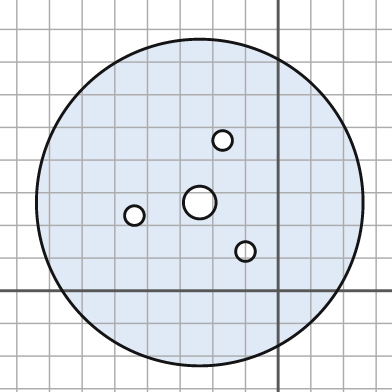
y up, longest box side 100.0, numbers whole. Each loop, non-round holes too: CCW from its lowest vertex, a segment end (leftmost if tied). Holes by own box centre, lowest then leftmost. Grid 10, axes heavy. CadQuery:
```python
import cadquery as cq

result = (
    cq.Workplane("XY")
    .moveTo(-24.0, 27.0)
    .circle(50.0)
    .moveTo(-10.0, 12.0)
    .circle(3.0)
    .moveTo(-44.0, 23.0)
    .circle(3.0)
    .moveTo(-24.0, 27.0)
    .circle(5.0)
    .moveTo(-17.0, 46.0)
    .circle(3.0)
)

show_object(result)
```